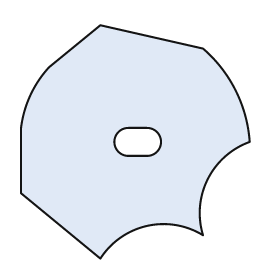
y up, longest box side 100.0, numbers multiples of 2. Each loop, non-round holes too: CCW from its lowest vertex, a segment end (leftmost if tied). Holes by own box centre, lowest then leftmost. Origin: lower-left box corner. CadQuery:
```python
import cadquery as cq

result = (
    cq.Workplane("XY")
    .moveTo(34.0, 0.0)
    .threePointArc((54.0, 14.0), (78.0, 10.0))
    .threePointArc((80.0, 34.0), (98.0, 50.0))
    .threePointArc((92.0, 72.0), (78.0, 90.0))
    .lineTo(34.0, 100.0)
    .lineTo(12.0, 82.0)
    .threePointArc((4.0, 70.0), (0.0, 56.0))
    .lineTo(0.0, 28.0)
    .close()
    .moveTo(46.0, 44.0)
    .lineTo(54.0, 44.0)
    .threePointArc((60.0, 50.0), (54.0, 56.0))
    .lineTo(46.0, 56.0)
    .threePointArc((40.0, 50.0), (46.0, 44.0))
    .close()
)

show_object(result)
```